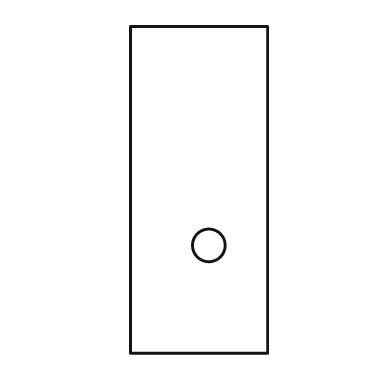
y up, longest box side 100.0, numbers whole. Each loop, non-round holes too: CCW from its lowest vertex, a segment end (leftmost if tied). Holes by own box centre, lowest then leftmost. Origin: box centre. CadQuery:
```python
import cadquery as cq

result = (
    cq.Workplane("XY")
    .moveTo(-21.0, -50.0)
    .lineTo(21.0, -50.0)
    .lineTo(21.0, 50.0)
    .lineTo(-21.0, 50.0)
    .close()
    .moveTo(3.0, -17.0)
    .circle(5.0)
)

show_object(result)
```